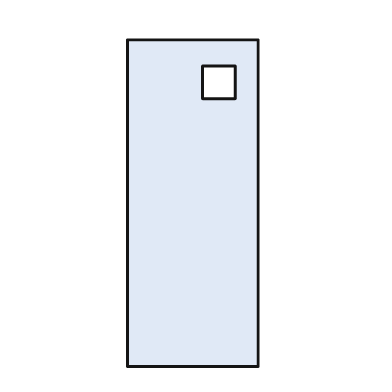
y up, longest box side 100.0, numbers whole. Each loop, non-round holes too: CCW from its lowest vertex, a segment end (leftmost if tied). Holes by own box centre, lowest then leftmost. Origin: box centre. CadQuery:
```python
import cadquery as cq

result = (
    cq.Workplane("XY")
    .moveTo(-20.0, -50.0)
    .lineTo(20.0, -50.0)
    .lineTo(20.0, 50.0)
    .lineTo(-20.0, 50.0)
    .close()
    .moveTo(3.0, 32.0)
    .lineTo(13.0, 32.0)
    .lineTo(13.0, 42.0)
    .lineTo(3.0, 42.0)
    .close()
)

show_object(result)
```